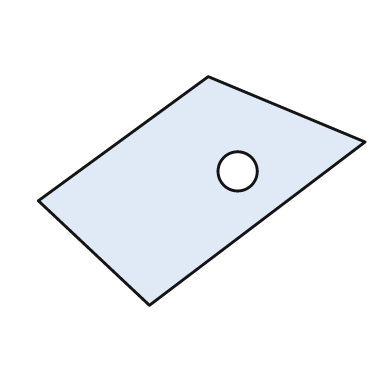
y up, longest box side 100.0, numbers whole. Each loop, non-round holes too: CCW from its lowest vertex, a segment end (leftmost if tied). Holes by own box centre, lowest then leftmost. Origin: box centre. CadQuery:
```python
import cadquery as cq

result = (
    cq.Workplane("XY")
    .moveTo(-16.0, -35.0)
    .lineTo(50.0, 15.0)
    .lineTo(2.0, 35.0)
    .lineTo(-50.0, -3.0)
    .close()
    .moveTo(11.0, 6.0)
    .circle(6.0)
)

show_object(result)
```